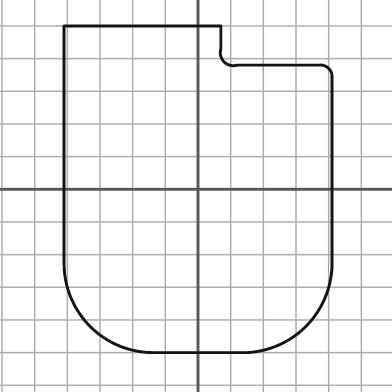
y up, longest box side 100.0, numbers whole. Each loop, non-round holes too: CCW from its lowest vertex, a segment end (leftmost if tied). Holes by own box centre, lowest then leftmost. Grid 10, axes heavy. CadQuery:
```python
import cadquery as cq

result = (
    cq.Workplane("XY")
    .moveTo(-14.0, -50.0)
    .lineTo(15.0, -50.0)
    .threePointArc((33.0, -42.0), (41.0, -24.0))
    .lineTo(41.0, 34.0)
    .threePointArc((40.0, 37.0), (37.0, 38.0))
    .lineTo(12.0, 38.0)
    .threePointArc((8.0, 39.0), (7.0, 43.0))
    .lineTo(7.0, 50.0)
    .lineTo(-41.0, 50.0)
    .lineTo(-41.0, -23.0)
    .threePointArc((-33.0, -42.0), (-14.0, -50.0))
    .close()
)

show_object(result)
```